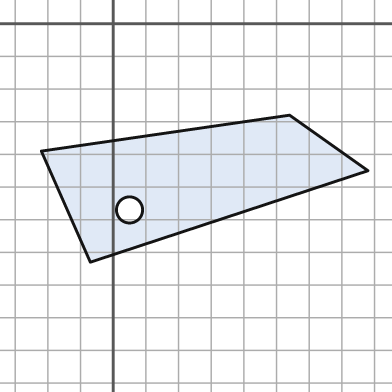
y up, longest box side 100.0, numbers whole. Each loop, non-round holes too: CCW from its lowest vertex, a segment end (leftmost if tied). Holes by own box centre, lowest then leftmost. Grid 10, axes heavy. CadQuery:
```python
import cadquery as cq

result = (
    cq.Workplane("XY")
    .moveTo(-7.0, -73.0)
    .lineTo(78.0, -45.0)
    .lineTo(54.0, -28.0)
    .lineTo(-22.0, -39.0)
    .close()
    .moveTo(5.0, -57.0)
    .circle(4.0)
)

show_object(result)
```